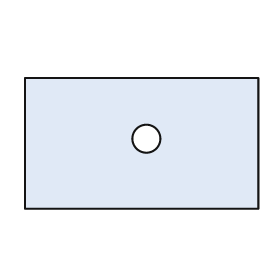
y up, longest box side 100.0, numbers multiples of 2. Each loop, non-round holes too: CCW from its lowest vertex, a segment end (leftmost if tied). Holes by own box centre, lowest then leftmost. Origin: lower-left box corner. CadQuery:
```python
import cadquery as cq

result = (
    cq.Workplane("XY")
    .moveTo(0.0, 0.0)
    .lineTo(100.0, 0.0)
    .lineTo(100.0, 56.0)
    .lineTo(0.0, 56.0)
    .close()
    .moveTo(52.0, 30.0)
    .circle(6.0)
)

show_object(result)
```